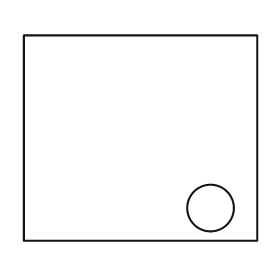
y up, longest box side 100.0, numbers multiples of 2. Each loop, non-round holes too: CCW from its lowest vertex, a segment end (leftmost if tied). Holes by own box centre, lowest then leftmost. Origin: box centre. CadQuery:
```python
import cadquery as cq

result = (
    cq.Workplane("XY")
    .moveTo(-50.0, -44.0)
    .lineTo(50.0, -44.0)
    .lineTo(50.0, 44.0)
    .lineTo(-50.0, 44.0)
    .close()
    .moveTo(30.0, -30.0)
    .circle(10.0)
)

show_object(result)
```